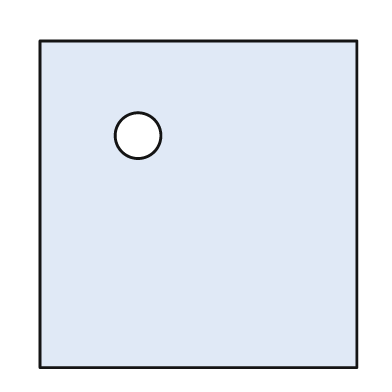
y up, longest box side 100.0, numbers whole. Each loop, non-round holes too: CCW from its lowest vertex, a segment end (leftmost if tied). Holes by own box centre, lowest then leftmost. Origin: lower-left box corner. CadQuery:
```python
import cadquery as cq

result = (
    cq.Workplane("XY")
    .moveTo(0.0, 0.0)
    .lineTo(97.0, 0.0)
    .lineTo(97.0, 100.0)
    .lineTo(0.0, 100.0)
    .close()
    .moveTo(30.0, 71.0)
    .circle(7.0)
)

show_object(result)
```